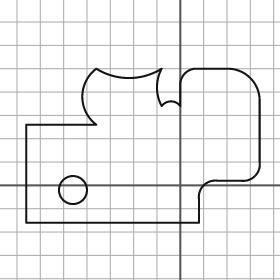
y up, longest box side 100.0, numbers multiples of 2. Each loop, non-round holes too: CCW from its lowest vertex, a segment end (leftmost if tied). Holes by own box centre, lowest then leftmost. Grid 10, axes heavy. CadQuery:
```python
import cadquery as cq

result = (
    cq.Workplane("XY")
    .moveTo(-66.0, -16.0)
    .lineTo(8.0, -16.0)
    .lineTo(8.0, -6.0)
    .threePointArc((10.0, 0.0), (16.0, 2.0))
    .lineTo(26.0, 2.0)
    .threePointArc((32.0, 4.0), (34.0, 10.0))
    .lineTo(34.0, 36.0)
    .threePointArc((30.0, 46.0), (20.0, 50.0))
    .lineTo(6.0, 50.0)
    .threePointArc((2.0, 48.0), (0.0, 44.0))
    .lineTo(0.0, 34.0)
    .threePointArc((-4.0, 36.0), (-8.0, 34.0))
    .threePointArc((-10.0, 42.0), (-8.0, 50.0))
    .threePointArc((-22.0, 46.0), (-36.0, 50.0))
    .threePointArc((-42.0, 38.0), (-36.0, 26.0))
    .lineTo(-66.0, 26.0)
    .close()
    .moveTo(-46.0, -2.0)
    .circle(6.0)
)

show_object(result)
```